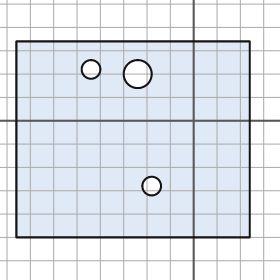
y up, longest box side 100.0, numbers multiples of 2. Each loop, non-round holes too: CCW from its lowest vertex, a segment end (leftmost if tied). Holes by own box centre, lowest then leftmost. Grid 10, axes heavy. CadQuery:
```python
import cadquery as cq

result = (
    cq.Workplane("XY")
    .moveTo(-76.0, -50.0)
    .lineTo(24.0, -50.0)
    .lineTo(24.0, 34.0)
    .lineTo(-76.0, 34.0)
    .close()
    .moveTo(-18.0, -28.0)
    .circle(4.0)
    .moveTo(-24.0, 20.0)
    .circle(6.0)
    .moveTo(-44.0, 22.0)
    .circle(4.0)
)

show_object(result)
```